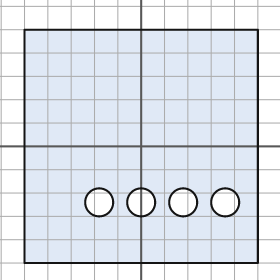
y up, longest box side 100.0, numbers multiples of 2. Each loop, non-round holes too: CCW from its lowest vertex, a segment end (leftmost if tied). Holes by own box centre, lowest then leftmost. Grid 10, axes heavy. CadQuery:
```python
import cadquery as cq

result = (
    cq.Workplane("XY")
    .moveTo(-50.0, -50.0)
    .lineTo(50.0, -50.0)
    .lineTo(50.0, 50.0)
    .lineTo(-50.0, 50.0)
    .close()
    .moveTo(-18.0, -24.0)
    .circle(6.0)
    .moveTo(0.0, -24.0)
    .circle(6.0)
    .moveTo(18.0, -24.0)
    .circle(6.0)
    .moveTo(36.0, -24.0)
    .circle(6.0)
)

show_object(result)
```